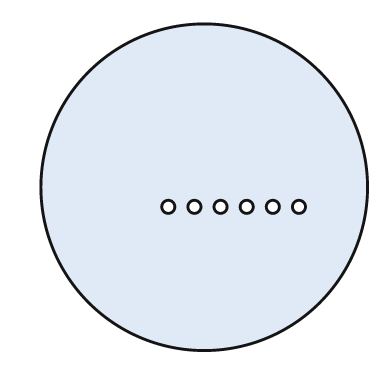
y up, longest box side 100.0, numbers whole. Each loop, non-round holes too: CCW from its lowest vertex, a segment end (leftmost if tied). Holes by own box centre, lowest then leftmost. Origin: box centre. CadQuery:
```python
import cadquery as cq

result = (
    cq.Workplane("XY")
    .moveTo(0.0, 0.0)
    .circle(50.0)
    .moveTo(-11.0, -6.0)
    .circle(2.0)
    .moveTo(-3.0, -6.0)
    .circle(2.0)
    .moveTo(5.0, -6.0)
    .circle(2.0)
    .moveTo(13.0, -6.0)
    .circle(2.0)
    .moveTo(21.0, -6.0)
    .circle(2.0)
    .moveTo(29.0, -6.0)
    .circle(2.0)
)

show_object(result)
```